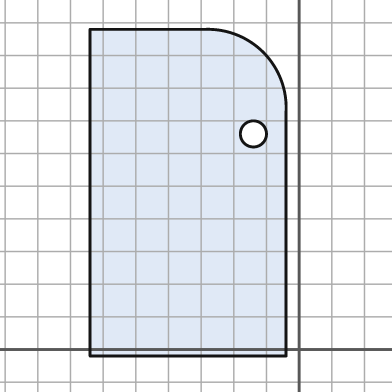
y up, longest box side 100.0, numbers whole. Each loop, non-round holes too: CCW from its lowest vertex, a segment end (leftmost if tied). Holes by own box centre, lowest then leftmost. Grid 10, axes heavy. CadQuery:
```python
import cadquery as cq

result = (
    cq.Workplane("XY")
    .moveTo(-64.0, -2.0)
    .lineTo(-4.0, -2.0)
    .lineTo(-4.0, 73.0)
    .threePointArc((-11.0, 91.0), (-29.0, 98.0))
    .lineTo(-64.0, 98.0)
    .close()
    .moveTo(-14.0, 66.0)
    .circle(4.0)
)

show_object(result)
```